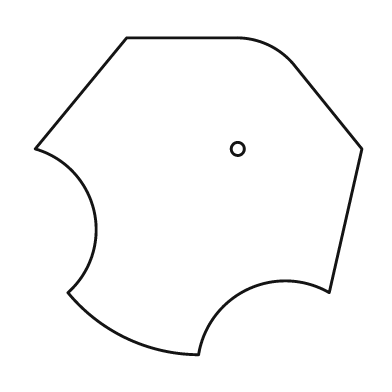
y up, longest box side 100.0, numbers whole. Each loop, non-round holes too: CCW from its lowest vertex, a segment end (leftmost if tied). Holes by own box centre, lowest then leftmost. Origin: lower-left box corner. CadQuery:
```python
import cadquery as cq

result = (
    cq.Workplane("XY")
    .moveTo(50.0, 0.0)
    .threePointArc((65.0, 20.0), (90.0, 19.0))
    .lineTo(100.0, 63.0)
    .lineTo(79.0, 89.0)
    .threePointArc((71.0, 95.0), (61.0, 97.0))
    .lineTo(28.0, 97.0)
    .lineTo(0.0, 63.0)
    .threePointArc((18.0, 44.0), (10.0, 19.0))
    .threePointArc((28.0, 5.0), (50.0, 0.0))
    .close()
    .moveTo(62.0, 63.0)
    .circle(2.0)
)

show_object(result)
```